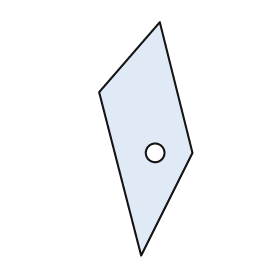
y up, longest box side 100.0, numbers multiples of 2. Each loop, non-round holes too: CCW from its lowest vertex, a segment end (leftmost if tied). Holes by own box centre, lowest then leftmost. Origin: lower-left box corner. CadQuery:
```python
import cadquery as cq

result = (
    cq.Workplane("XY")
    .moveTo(18.0, 0.0)
    .lineTo(40.0, 44.0)
    .lineTo(26.0, 100.0)
    .lineTo(0.0, 70.0)
    .close()
    .moveTo(24.0, 44.0)
    .circle(4.0)
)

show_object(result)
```